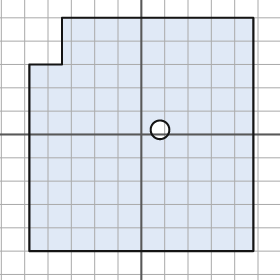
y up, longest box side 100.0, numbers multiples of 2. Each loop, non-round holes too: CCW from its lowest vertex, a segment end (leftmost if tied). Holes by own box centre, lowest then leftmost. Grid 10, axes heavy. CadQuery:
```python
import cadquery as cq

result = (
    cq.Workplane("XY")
    .moveTo(-48.0, -50.0)
    .lineTo(48.0, -50.0)
    .lineTo(48.0, 50.0)
    .lineTo(-34.0, 50.0)
    .lineTo(-34.0, 30.0)
    .lineTo(-48.0, 30.0)
    .close()
    .moveTo(8.0, 2.0)
    .circle(4.0)
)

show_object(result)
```